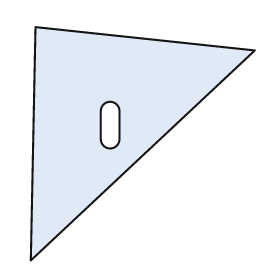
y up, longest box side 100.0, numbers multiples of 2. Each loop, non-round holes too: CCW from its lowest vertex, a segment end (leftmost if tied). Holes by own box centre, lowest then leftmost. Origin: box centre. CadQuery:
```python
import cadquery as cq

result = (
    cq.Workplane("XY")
    .moveTo(-48.0, -50.0)
    .lineTo(48.0, 40.0)
    .lineTo(-46.0, 50.0)
    .close()
    .moveTo(-18.0, 2.0)
    .threePointArc((-14.0, -2.0), (-10.0, 2.0))
    .lineTo(-10.0, 14.0)
    .threePointArc((-14.0, 18.0), (-18.0, 14.0))
    .close()
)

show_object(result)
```